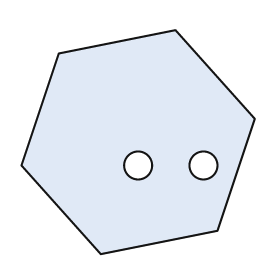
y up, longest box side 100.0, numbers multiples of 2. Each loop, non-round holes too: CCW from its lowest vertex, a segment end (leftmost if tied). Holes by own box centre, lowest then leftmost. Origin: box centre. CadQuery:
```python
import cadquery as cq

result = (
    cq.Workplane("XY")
    .moveTo(-16.0, -48.0)
    .lineTo(34.0, -38.0)
    .lineTo(50.0, 10.0)
    .lineTo(16.0, 48.0)
    .lineTo(-34.0, 38.0)
    .lineTo(-50.0, -10.0)
    .close()
    .moveTo(0.0, -10.0)
    .circle(6.0)
    .moveTo(28.0, -10.0)
    .circle(6.0)
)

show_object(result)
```